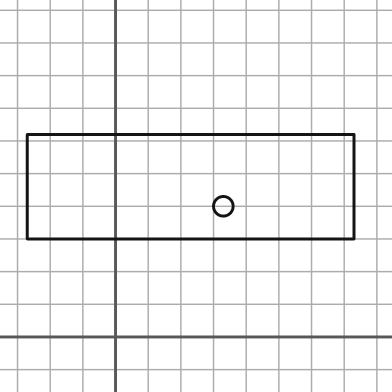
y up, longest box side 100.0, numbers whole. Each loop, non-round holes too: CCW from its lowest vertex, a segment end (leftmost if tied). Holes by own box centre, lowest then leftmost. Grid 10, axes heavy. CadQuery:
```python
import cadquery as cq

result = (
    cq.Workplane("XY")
    .moveTo(-27.0, 30.0)
    .lineTo(73.0, 30.0)
    .lineTo(73.0, 62.0)
    .lineTo(-27.0, 62.0)
    .close()
    .moveTo(33.0, 40.0)
    .circle(3.0)
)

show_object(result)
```